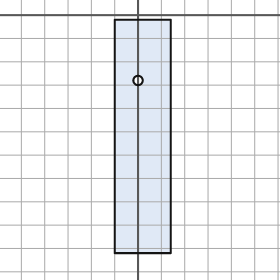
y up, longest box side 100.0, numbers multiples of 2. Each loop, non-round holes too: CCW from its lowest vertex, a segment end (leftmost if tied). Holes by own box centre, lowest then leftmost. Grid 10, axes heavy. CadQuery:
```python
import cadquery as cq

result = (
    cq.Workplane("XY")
    .moveTo(-10.0, -102.0)
    .lineTo(14.0, -102.0)
    .lineTo(14.0, -2.0)
    .lineTo(-10.0, -2.0)
    .close()
    .moveTo(0.0, -28.0)
    .circle(2.0)
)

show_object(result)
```